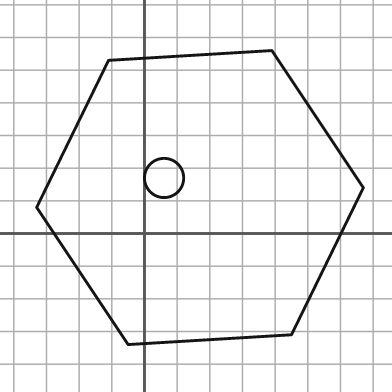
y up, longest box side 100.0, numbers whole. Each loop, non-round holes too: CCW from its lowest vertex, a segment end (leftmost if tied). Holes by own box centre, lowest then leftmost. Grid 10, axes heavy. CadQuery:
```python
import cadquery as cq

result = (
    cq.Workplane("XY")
    .moveTo(-5.0, -34.0)
    .lineTo(45.0, -31.0)
    .lineTo(67.0, 14.0)
    .lineTo(39.0, 56.0)
    .lineTo(-11.0, 53.0)
    .lineTo(-33.0, 8.0)
    .close()
    .moveTo(6.0, 17.0)
    .circle(6.0)
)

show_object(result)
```